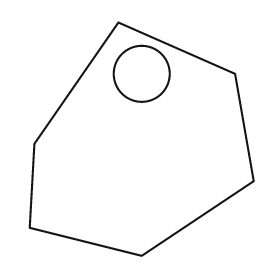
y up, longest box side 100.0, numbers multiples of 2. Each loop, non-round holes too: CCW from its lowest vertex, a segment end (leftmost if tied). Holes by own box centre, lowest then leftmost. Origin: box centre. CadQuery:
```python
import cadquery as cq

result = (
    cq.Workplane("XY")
    .moveTo(0.0, -50.0)
    .lineTo(48.0, -18.0)
    .lineTo(40.0, 28.0)
    .lineTo(-10.0, 50.0)
    .lineTo(-46.0, -2.0)
    .lineTo(-48.0, -38.0)
    .close()
    .moveTo(0.0, 28.0)
    .circle(12.0)
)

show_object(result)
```